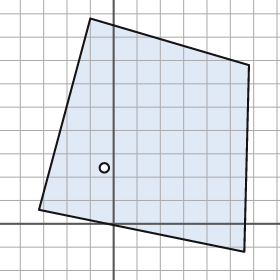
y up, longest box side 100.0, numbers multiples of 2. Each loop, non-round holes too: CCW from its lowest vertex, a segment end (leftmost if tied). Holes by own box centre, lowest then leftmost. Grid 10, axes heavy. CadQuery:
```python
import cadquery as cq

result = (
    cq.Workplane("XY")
    .moveTo(56.0, -12.0)
    .lineTo(58.0, 68.0)
    .lineTo(-10.0, 88.0)
    .lineTo(-32.0, 6.0)
    .close()
    .moveTo(-4.0, 24.0)
    .circle(2.0)
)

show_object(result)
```